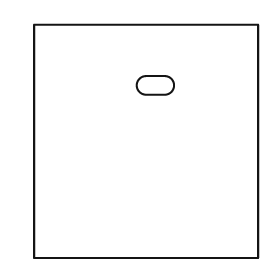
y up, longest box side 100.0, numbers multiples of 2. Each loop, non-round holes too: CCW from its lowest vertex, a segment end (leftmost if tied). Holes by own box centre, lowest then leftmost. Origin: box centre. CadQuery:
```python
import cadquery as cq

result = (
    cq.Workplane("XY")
    .moveTo(-48.0, -50.0)
    .lineTo(48.0, -50.0)
    .lineTo(48.0, 50.0)
    .lineTo(-48.0, 50.0)
    .close()
    .moveTo(0.0, 20.0)
    .lineTo(8.0, 20.0)
    .threePointArc((12.0, 24.0), (8.0, 28.0))
    .lineTo(0.0, 28.0)
    .threePointArc((-4.0, 24.0), (0.0, 20.0))
    .close()
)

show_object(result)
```